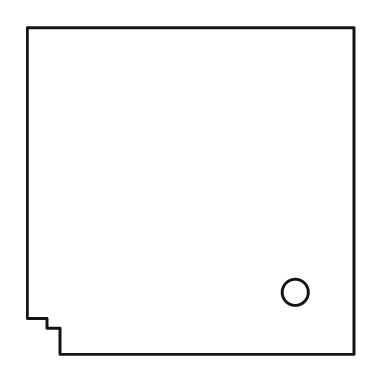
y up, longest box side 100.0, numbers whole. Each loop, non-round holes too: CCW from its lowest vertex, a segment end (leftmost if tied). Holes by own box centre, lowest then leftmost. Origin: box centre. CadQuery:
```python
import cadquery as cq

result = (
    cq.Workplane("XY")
    .moveTo(-40.0, -50.0)
    .lineTo(50.0, -50.0)
    .lineTo(50.0, 50.0)
    .lineTo(-50.0, 50.0)
    .lineTo(-50.0, -39.0)
    .lineTo(-44.0, -39.0)
    .lineTo(-44.0, -42.0)
    .lineTo(-40.0, -42.0)
    .close()
    .moveTo(32.0, -31.0)
    .circle(4.0)
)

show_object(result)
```